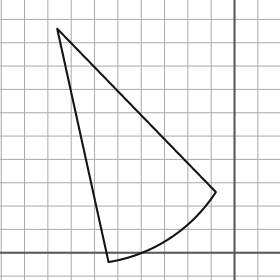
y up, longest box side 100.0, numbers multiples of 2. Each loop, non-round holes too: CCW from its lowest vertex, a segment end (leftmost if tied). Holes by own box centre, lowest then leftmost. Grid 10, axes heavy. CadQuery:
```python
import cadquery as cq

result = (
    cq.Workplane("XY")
    .moveTo(-54.0, -4.0)
    .threePointArc((-28.0, 6.0), (-8.0, 26.0))
    .lineTo(-76.0, 96.0)
    .close()
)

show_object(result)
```